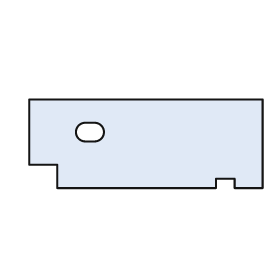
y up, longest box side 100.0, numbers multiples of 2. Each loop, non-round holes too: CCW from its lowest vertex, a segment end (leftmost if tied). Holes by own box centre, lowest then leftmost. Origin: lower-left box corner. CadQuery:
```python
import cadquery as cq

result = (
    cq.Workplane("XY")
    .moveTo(12.0, 0.0)
    .lineTo(80.0, 0.0)
    .lineTo(80.0, 4.0)
    .lineTo(88.0, 4.0)
    .lineTo(88.0, 0.0)
    .lineTo(100.0, 0.0)
    .lineTo(100.0, 38.0)
    .lineTo(0.0, 38.0)
    .lineTo(0.0, 10.0)
    .lineTo(12.0, 10.0)
    .close()
    .moveTo(24.0, 20.0)
    .lineTo(28.0, 20.0)
    .threePointArc((32.0, 24.0), (28.0, 28.0))
    .lineTo(24.0, 28.0)
    .threePointArc((20.0, 24.0), (24.0, 20.0))
    .close()
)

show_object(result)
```